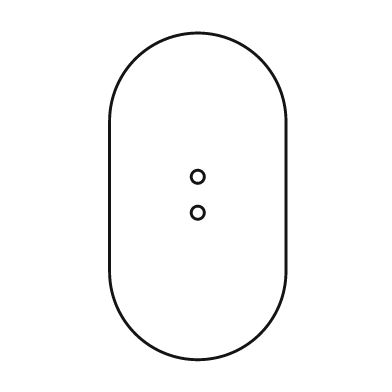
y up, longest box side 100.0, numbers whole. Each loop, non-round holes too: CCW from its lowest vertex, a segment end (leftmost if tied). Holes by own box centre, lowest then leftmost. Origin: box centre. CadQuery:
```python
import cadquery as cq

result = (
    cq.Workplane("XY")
    .moveTo(-27.0, -23.0)
    .threePointArc((0.0, -50.0), (27.0, -23.0))
    .lineTo(27.0, 23.0)
    .threePointArc((0.0, 50.0), (-27.0, 23.0))
    .close()
    .moveTo(0.0, -5.0)
    .circle(2.0)
    .moveTo(0.0, 6.0)
    .circle(2.0)
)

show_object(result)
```